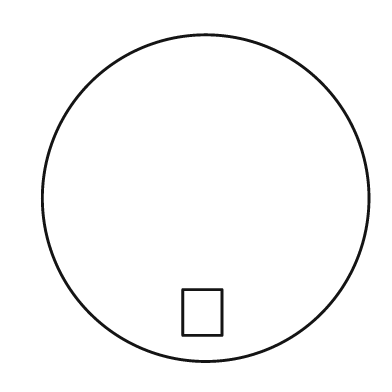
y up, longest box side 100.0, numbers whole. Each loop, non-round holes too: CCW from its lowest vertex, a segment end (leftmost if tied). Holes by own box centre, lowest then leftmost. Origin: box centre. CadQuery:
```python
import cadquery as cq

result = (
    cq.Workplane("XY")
    .moveTo(0.0, 0.0)
    .circle(50.0)
    .moveTo(-7.0, -42.0)
    .lineTo(5.0, -42.0)
    .lineTo(5.0, -28.0)
    .lineTo(-7.0, -28.0)
    .close()
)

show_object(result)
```